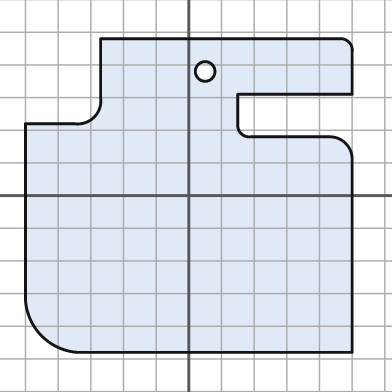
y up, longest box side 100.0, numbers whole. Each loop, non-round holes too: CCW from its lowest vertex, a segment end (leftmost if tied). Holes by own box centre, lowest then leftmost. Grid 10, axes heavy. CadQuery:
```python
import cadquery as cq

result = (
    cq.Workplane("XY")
    .moveTo(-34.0, -48.0)
    .lineTo(50.0, -48.0)
    .lineTo(50.0, 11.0)
    .threePointArc((48.0, 16.0), (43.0, 18.0))
    .lineTo(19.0, 18.0)
    .threePointArc((16.0, 19.0), (15.0, 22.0))
    .lineTo(15.0, 31.0)
    .lineTo(50.0, 31.0)
    .lineTo(50.0, 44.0)
    .threePointArc((49.0, 47.0), (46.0, 48.0))
    .lineTo(-27.0, 48.0)
    .lineTo(-27.0, 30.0)
    .threePointArc((-29.0, 24.0), (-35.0, 22.0))
    .lineTo(-50.0, 22.0)
    .lineTo(-50.0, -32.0)
    .threePointArc((-45.0, -43.0), (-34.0, -48.0))
    .close()
    .moveTo(5.0, 38.0)
    .circle(3.0)
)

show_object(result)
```